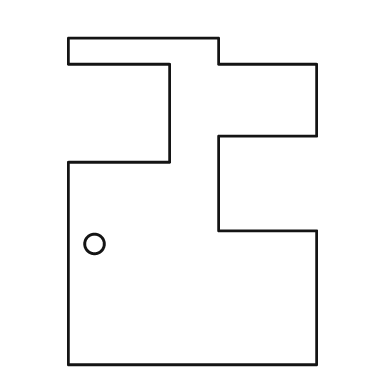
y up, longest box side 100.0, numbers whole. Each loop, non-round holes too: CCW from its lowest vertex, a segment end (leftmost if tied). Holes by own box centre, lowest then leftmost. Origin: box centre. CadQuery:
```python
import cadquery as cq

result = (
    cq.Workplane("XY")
    .moveTo(-38.0, -50.0)
    .lineTo(38.0, -50.0)
    .lineTo(38.0, -9.0)
    .lineTo(8.0, -9.0)
    .lineTo(8.0, 20.0)
    .lineTo(38.0, 20.0)
    .lineTo(38.0, 42.0)
    .lineTo(8.0, 42.0)
    .lineTo(8.0, 50.0)
    .lineTo(-38.0, 50.0)
    .lineTo(-38.0, 42.0)
    .lineTo(-7.0, 42.0)
    .lineTo(-7.0, 12.0)
    .lineTo(-38.0, 12.0)
    .close()
    .moveTo(-30.0, -13.0)
    .circle(3.0)
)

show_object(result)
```